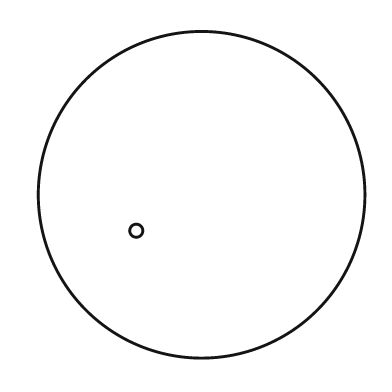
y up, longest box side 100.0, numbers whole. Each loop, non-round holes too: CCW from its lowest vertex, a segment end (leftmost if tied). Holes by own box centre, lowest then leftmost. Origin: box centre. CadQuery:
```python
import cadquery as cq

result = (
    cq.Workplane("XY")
    .moveTo(0.0, 0.0)
    .circle(50.0)
    .moveTo(-20.0, -11.0)
    .circle(2.0)
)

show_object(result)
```